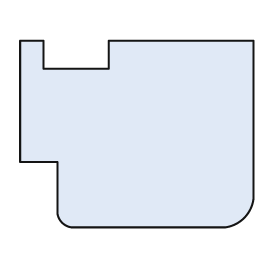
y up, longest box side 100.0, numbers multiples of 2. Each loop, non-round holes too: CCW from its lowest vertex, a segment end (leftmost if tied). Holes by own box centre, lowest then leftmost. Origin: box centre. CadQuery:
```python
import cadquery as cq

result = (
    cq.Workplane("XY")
    .moveTo(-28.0, -40.0)
    .lineTo(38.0, -40.0)
    .threePointArc((46.0, -36.0), (50.0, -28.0))
    .lineTo(50.0, 40.0)
    .lineTo(-12.0, 40.0)
    .lineTo(-12.0, 28.0)
    .lineTo(-40.0, 28.0)
    .lineTo(-40.0, 40.0)
    .lineTo(-50.0, 40.0)
    .lineTo(-50.0, -12.0)
    .lineTo(-34.0, -12.0)
    .lineTo(-34.0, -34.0)
    .threePointArc((-32.0, -38.0), (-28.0, -40.0))
    .close()
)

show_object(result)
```